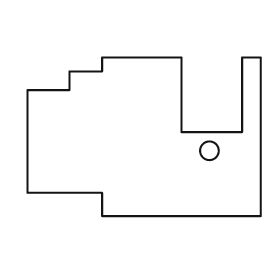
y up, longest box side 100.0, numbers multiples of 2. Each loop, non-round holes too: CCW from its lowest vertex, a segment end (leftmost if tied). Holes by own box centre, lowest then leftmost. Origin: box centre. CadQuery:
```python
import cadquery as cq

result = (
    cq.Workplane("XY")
    .moveTo(-18.0, -34.0)
    .lineTo(50.0, -34.0)
    .lineTo(50.0, 34.0)
    .lineTo(42.0, 34.0)
    .lineTo(42.0, 2.0)
    .lineTo(16.0, 2.0)
    .lineTo(16.0, 34.0)
    .lineTo(-18.0, 34.0)
    .lineTo(-18.0, 28.0)
    .lineTo(-32.0, 28.0)
    .lineTo(-32.0, 20.0)
    .lineTo(-50.0, 20.0)
    .lineTo(-50.0, -24.0)
    .lineTo(-18.0, -24.0)
    .close()
    .moveTo(28.0, -6.0)
    .circle(4.0)
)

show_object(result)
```